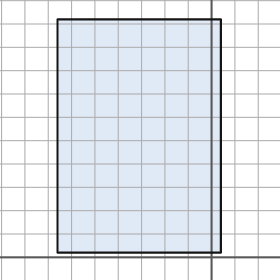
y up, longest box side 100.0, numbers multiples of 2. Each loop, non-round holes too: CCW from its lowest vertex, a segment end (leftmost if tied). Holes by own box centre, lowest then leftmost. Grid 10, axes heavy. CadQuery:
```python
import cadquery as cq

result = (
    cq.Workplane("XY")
    .moveTo(-66.0, 2.0)
    .lineTo(4.0, 2.0)
    .lineTo(4.0, 102.0)
    .lineTo(-66.0, 102.0)
    .close()
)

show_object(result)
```